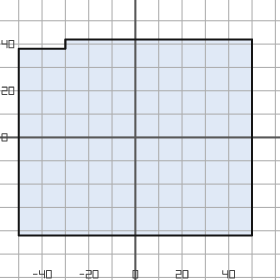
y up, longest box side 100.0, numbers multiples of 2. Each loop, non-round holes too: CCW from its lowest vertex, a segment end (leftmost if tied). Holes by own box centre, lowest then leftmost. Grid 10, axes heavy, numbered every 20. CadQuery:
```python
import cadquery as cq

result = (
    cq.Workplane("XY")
    .moveTo(-50.0, -42.0)
    .lineTo(50.0, -42.0)
    .lineTo(50.0, 42.0)
    .lineTo(-30.0, 42.0)
    .lineTo(-30.0, 38.0)
    .lineTo(-50.0, 38.0)
    .close()
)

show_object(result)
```